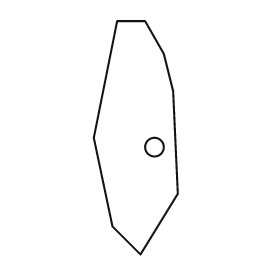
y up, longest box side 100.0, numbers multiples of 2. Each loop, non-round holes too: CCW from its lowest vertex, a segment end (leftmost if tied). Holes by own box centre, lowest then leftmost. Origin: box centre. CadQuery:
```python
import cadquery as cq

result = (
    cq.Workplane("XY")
    .moveTo(2.0, -50.0)
    .lineTo(18.0, -24.0)
    .lineTo(16.0, 20.0)
    .lineTo(12.0, 36.0)
    .lineTo(4.0, 50.0)
    .lineTo(-8.0, 50.0)
    .lineTo(-18.0, 0.0)
    .lineTo(-10.0, -38.0)
    .close()
    .moveTo(8.0, -4.0)
    .circle(4.0)
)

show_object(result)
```